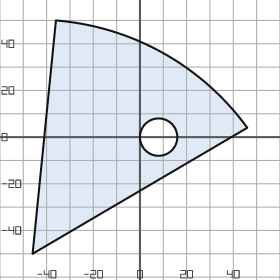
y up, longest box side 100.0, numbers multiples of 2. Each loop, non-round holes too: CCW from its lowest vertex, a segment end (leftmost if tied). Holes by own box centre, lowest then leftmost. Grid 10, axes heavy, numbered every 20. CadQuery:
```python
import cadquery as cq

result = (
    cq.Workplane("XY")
    .moveTo(-46.0, -50.0)
    .lineTo(46.0, 4.0)
    .threePointArc((10.0, 36.0), (-36.0, 50.0))
    .close()
    .moveTo(8.0, 0.0)
    .circle(8.0)
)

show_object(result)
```